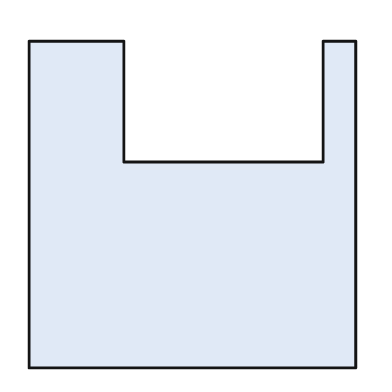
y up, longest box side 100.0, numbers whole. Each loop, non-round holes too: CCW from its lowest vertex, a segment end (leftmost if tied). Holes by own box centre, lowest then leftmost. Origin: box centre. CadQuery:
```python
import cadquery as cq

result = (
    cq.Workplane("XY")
    .moveTo(-50.0, -50.0)
    .lineTo(50.0, -50.0)
    .lineTo(50.0, 50.0)
    .lineTo(40.0, 50.0)
    .lineTo(40.0, 13.0)
    .lineTo(-21.0, 13.0)
    .lineTo(-21.0, 50.0)
    .lineTo(-50.0, 50.0)
    .close()
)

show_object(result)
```